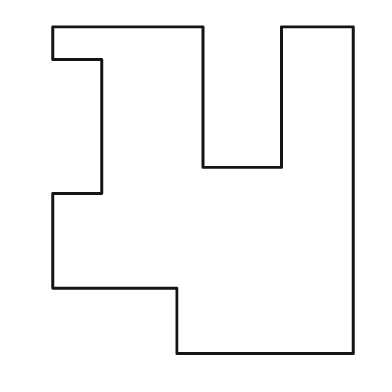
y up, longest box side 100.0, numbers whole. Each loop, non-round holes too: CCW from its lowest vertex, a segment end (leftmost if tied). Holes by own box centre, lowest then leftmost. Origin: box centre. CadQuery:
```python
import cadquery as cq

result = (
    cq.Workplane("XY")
    .moveTo(-8.0, -50.0)
    .lineTo(46.0, -50.0)
    .lineTo(46.0, 50.0)
    .lineTo(24.0, 50.0)
    .lineTo(24.0, 7.0)
    .lineTo(0.0, 7.0)
    .lineTo(0.0, 50.0)
    .lineTo(-46.0, 50.0)
    .lineTo(-46.0, 40.0)
    .lineTo(-31.0, 40.0)
    .lineTo(-31.0, -1.0)
    .lineTo(-46.0, -1.0)
    .lineTo(-46.0, -30.0)
    .lineTo(-8.0, -30.0)
    .close()
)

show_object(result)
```